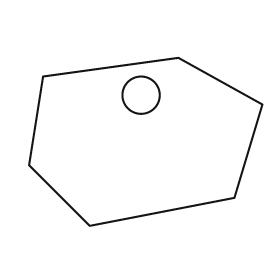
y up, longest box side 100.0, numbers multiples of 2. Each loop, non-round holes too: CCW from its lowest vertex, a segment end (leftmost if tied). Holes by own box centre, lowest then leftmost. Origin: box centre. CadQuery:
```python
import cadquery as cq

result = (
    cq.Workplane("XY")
    .moveTo(-24.0, -36.0)
    .lineTo(38.0, -24.0)
    .lineTo(50.0, 16.0)
    .lineTo(14.0, 36.0)
    .lineTo(-44.0, 28.0)
    .lineTo(-50.0, -10.0)
    .close()
    .moveTo(-2.0, 20.0)
    .circle(8.0)
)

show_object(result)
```